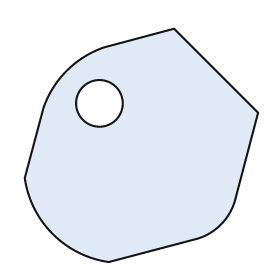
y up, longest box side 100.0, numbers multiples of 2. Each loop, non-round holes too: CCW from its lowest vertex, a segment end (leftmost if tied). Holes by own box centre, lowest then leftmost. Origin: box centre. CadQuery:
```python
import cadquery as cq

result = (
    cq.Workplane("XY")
    .moveTo(-14.0, -50.0)
    .lineTo(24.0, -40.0)
    .threePointArc((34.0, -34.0), (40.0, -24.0))
    .lineTo(50.0, 14.0)
    .lineTo(14.0, 50.0)
    .lineTo(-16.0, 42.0)
    .threePointArc((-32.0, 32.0), (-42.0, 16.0))
    .lineTo(-50.0, -14.0)
    .threePointArc((-38.0, -38.0), (-14.0, -50.0))
    .close()
    .moveTo(-18.0, 18.0)
    .circle(10.0)
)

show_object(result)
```